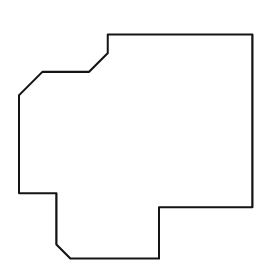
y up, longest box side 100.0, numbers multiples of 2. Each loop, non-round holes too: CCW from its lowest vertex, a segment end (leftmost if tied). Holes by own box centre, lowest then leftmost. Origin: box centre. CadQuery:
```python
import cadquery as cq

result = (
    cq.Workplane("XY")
    .moveTo(-28.0, -48.0)
    .lineTo(10.0, -48.0)
    .lineTo(10.0, -26.0)
    .lineTo(50.0, -26.0)
    .lineTo(50.0, 48.0)
    .lineTo(-12.0, 48.0)
    .lineTo(-12.0, 40.0)
    .lineTo(-20.0, 32.0)
    .lineTo(-40.0, 32.0)
    .lineTo(-50.0, 22.0)
    .lineTo(-50.0, -20.0)
    .lineTo(-34.0, -20.0)
    .lineTo(-34.0, -42.0)
    .close()
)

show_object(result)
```